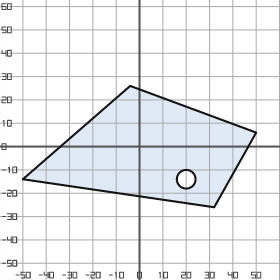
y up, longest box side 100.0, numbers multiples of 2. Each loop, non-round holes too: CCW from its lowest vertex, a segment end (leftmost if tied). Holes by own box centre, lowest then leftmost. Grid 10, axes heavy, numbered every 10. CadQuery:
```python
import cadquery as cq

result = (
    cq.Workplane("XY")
    .moveTo(32.0, -26.0)
    .lineTo(50.0, 6.0)
    .lineTo(-4.0, 26.0)
    .lineTo(-50.0, -14.0)
    .close()
    .moveTo(20.0, -14.0)
    .circle(4.0)
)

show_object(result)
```